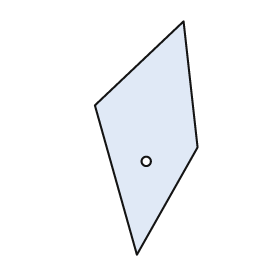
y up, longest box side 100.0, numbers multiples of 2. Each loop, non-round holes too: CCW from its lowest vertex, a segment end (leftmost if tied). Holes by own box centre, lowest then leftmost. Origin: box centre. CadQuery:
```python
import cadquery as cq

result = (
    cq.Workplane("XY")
    .moveTo(-4.0, -50.0)
    .lineTo(22.0, -4.0)
    .lineTo(16.0, 50.0)
    .lineTo(-22.0, 14.0)
    .close()
    .moveTo(0.0, -10.0)
    .circle(2.0)
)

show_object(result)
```